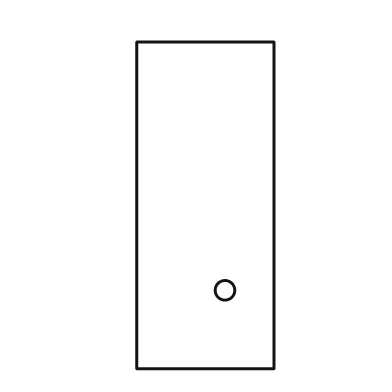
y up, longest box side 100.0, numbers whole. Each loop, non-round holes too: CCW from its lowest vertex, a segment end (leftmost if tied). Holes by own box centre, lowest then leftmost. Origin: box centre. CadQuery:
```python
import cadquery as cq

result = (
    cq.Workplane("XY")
    .moveTo(-21.0, -50.0)
    .lineTo(21.0, -50.0)
    .lineTo(21.0, 50.0)
    .lineTo(-21.0, 50.0)
    .close()
    .moveTo(6.0, -26.0)
    .circle(3.0)
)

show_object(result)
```